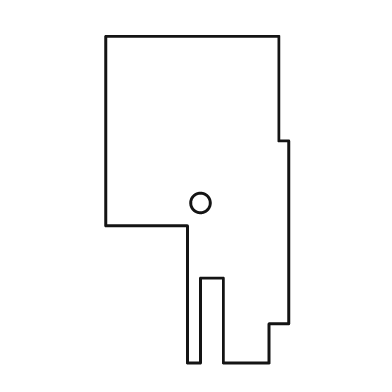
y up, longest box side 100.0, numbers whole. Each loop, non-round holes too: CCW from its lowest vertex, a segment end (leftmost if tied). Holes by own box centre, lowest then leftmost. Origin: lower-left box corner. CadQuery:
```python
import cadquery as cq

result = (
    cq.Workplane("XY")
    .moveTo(25.0, 0.0)
    .lineTo(29.0, 0.0)
    .lineTo(29.0, 26.0)
    .lineTo(36.0, 26.0)
    .lineTo(36.0, 0.0)
    .lineTo(50.0, 0.0)
    .lineTo(50.0, 12.0)
    .lineTo(56.0, 12.0)
    .lineTo(56.0, 68.0)
    .lineTo(53.0, 68.0)
    .lineTo(53.0, 100.0)
    .lineTo(0.0, 100.0)
    .lineTo(0.0, 42.0)
    .lineTo(25.0, 42.0)
    .close()
    .moveTo(29.0, 49.0)
    .circle(3.0)
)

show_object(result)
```